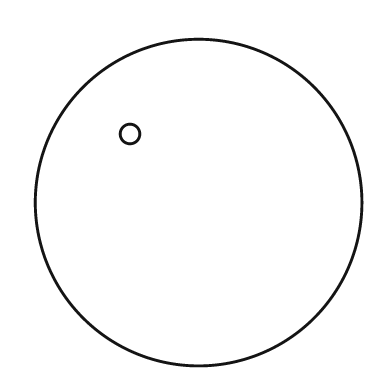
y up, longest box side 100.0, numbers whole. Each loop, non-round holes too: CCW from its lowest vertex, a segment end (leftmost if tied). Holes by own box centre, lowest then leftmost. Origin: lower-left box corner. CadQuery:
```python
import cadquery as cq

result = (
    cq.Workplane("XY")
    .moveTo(50.0, 50.0)
    .circle(50.0)
    .moveTo(29.0, 71.0)
    .circle(3.0)
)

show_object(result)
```